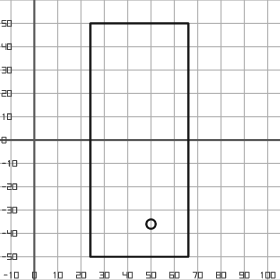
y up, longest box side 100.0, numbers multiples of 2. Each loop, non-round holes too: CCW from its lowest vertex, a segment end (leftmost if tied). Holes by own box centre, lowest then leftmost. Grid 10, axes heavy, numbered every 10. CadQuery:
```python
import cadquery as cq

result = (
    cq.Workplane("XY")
    .moveTo(24.0, -50.0)
    .lineTo(66.0, -50.0)
    .lineTo(66.0, 50.0)
    .lineTo(24.0, 50.0)
    .close()
    .moveTo(50.0, -36.0)
    .circle(2.0)
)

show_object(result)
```